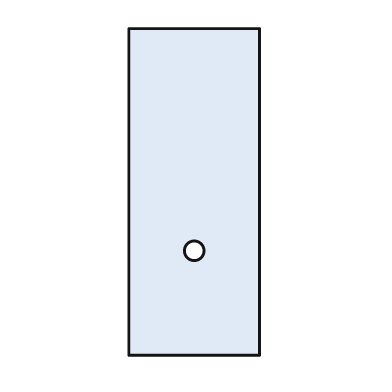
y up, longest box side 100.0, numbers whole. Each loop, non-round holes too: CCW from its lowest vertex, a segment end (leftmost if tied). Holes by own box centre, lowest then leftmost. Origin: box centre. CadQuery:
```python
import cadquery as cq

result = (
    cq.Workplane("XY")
    .moveTo(-20.0, -50.0)
    .lineTo(20.0, -50.0)
    .lineTo(20.0, 50.0)
    .lineTo(-20.0, 50.0)
    .close()
    .moveTo(0.0, -18.0)
    .circle(3.0)
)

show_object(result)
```